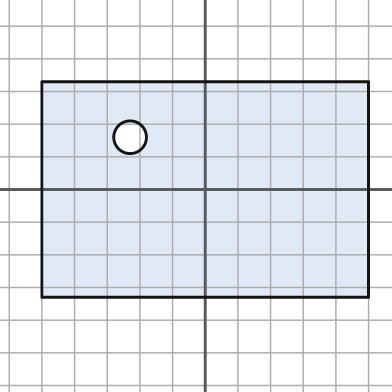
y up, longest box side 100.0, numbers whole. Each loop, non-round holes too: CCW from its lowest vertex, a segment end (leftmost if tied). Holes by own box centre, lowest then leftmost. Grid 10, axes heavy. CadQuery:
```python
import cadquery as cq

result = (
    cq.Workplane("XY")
    .moveTo(-50.0, -33.0)
    .lineTo(50.0, -33.0)
    .lineTo(50.0, 33.0)
    .lineTo(-50.0, 33.0)
    .close()
    .moveTo(-23.0, 16.0)
    .circle(5.0)
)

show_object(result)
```